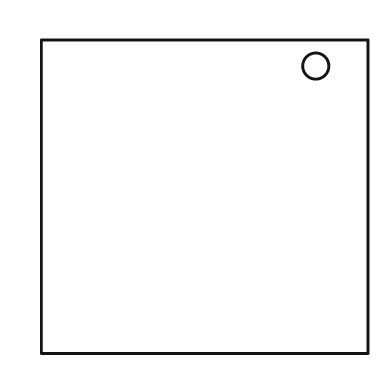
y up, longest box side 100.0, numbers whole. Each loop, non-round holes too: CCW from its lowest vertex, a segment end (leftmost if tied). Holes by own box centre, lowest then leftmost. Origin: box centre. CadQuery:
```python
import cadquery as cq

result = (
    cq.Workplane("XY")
    .moveTo(-50.0, -48.0)
    .lineTo(50.0, -48.0)
    .lineTo(50.0, 48.0)
    .lineTo(-50.0, 48.0)
    .close()
    .moveTo(34.0, 40.0)
    .circle(4.0)
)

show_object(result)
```